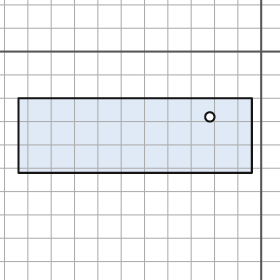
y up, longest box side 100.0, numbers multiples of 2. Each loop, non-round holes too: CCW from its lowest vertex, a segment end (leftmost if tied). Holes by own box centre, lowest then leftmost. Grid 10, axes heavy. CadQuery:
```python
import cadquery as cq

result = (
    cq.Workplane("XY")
    .moveTo(-104.0, -52.0)
    .lineTo(-4.0, -52.0)
    .lineTo(-4.0, -20.0)
    .lineTo(-104.0, -20.0)
    .close()
    .moveTo(-22.0, -28.0)
    .circle(2.0)
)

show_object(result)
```